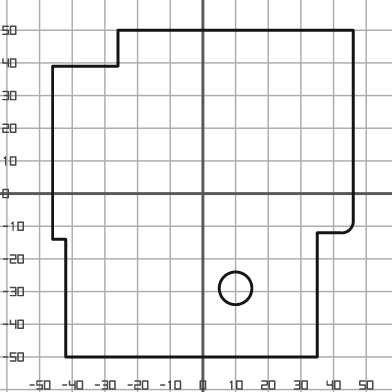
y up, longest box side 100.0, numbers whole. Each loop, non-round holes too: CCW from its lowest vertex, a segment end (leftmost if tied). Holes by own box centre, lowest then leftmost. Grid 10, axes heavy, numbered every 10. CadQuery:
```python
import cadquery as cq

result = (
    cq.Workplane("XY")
    .moveTo(-42.0, -50.0)
    .lineTo(35.0, -50.0)
    .lineTo(35.0, -12.0)
    .lineTo(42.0, -12.0)
    .threePointArc((45.0, -11.0), (46.0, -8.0))
    .lineTo(46.0, 50.0)
    .lineTo(-26.0, 50.0)
    .lineTo(-26.0, 39.0)
    .lineTo(-46.0, 39.0)
    .lineTo(-46.0, -14.0)
    .lineTo(-42.0, -14.0)
    .close()
    .moveTo(10.0, -29.0)
    .circle(5.0)
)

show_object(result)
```